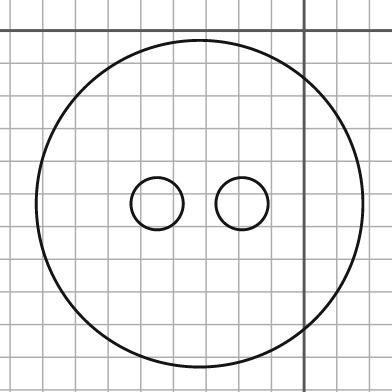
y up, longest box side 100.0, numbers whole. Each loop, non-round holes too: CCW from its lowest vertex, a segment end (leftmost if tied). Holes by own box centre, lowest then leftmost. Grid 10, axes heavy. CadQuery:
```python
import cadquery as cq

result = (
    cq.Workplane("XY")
    .moveTo(-32.0, -53.0)
    .circle(50.0)
    .moveTo(-45.0, -53.0)
    .circle(8.0)
    .moveTo(-19.0, -53.0)
    .circle(8.0)
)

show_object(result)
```